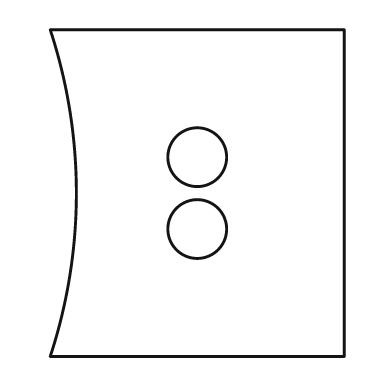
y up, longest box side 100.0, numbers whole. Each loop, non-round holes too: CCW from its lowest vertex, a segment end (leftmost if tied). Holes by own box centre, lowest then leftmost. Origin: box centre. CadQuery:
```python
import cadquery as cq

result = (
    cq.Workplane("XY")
    .moveTo(-45.0, -50.0)
    .lineTo(45.0, -50.0)
    .lineTo(45.0, 50.0)
    .lineTo(-45.0, 50.0)
    .threePointArc((-37.0, 0.0), (-45.0, -50.0))
    .close()
    .moveTo(0.0, -11.0)
    .circle(9.0)
    .moveTo(0.0, 11.0)
    .circle(9.0)
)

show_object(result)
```